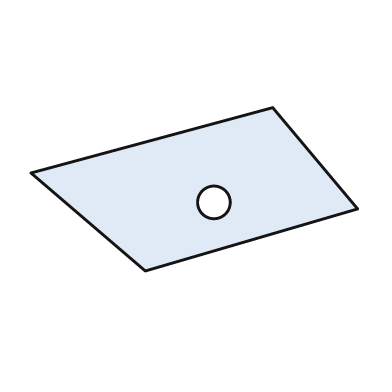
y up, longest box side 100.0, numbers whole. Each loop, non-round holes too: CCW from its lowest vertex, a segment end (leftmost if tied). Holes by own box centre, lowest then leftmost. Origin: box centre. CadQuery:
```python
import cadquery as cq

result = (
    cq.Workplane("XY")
    .moveTo(-15.0, -25.0)
    .lineTo(50.0, -6.0)
    .lineTo(24.0, 25.0)
    .lineTo(-50.0, 5.0)
    .close()
    .moveTo(6.0, -4.0)
    .circle(5.0)
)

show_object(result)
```